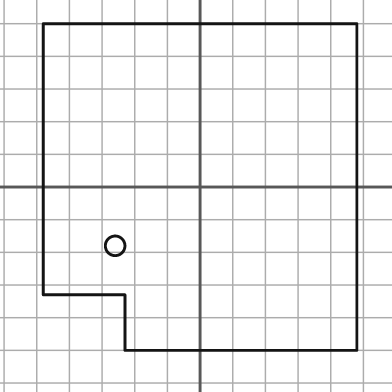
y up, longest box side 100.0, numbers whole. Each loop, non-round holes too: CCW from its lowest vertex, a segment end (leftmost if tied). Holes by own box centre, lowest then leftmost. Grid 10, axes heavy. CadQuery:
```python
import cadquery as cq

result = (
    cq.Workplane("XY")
    .moveTo(-23.0, -50.0)
    .lineTo(48.0, -50.0)
    .lineTo(48.0, 50.0)
    .lineTo(-48.0, 50.0)
    .lineTo(-48.0, -33.0)
    .lineTo(-23.0, -33.0)
    .close()
    .moveTo(-26.0, -18.0)
    .circle(3.0)
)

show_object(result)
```